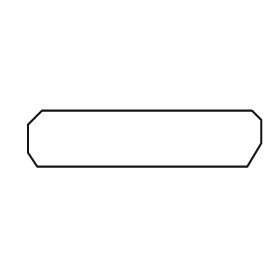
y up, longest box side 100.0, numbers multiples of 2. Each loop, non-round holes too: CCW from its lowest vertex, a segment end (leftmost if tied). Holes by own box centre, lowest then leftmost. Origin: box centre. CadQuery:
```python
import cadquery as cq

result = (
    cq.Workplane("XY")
    .moveTo(-46.0, -12.0)
    .lineTo(44.0, -12.0)
    .lineTo(50.0, -2.0)
    .lineTo(50.0, 8.0)
    .lineTo(46.0, 12.0)
    .lineTo(-44.0, 12.0)
    .lineTo(-50.0, 6.0)
    .lineTo(-50.0, -6.0)
    .close()
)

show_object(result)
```